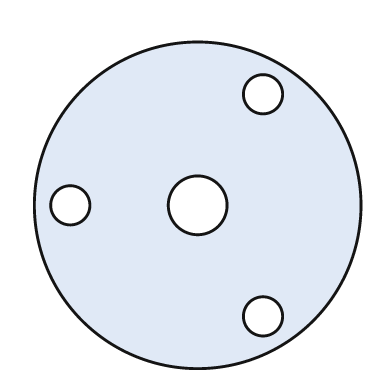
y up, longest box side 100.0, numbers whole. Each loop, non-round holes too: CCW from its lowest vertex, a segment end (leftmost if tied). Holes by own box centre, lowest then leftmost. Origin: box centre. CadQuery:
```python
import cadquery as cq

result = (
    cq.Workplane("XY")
    .moveTo(0.0, 0.0)
    .circle(50.0)
    .moveTo(20.0, -34.0)
    .circle(6.0)
    .moveTo(-39.0, 0.0)
    .circle(6.0)
    .moveTo(0.0, 0.0)
    .circle(9.0)
    .moveTo(20.0, 34.0)
    .circle(6.0)
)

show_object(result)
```